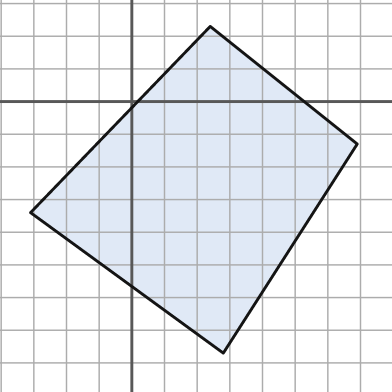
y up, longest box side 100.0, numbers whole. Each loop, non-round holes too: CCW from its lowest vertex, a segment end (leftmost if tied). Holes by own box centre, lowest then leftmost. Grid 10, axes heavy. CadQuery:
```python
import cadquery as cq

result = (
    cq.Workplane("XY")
    .moveTo(28.0, -77.0)
    .lineTo(69.0, -13.0)
    .lineTo(24.0, 23.0)
    .lineTo(-31.0, -34.0)
    .close()
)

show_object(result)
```